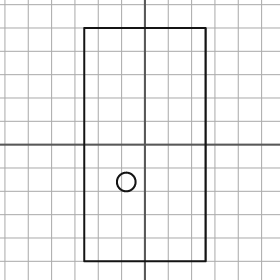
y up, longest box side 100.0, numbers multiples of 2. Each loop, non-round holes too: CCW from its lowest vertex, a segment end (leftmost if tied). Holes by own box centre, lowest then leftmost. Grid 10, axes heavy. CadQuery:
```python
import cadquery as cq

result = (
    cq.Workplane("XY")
    .moveTo(-26.0, -50.0)
    .lineTo(26.0, -50.0)
    .lineTo(26.0, 50.0)
    .lineTo(-26.0, 50.0)
    .close()
    .moveTo(-8.0, -16.0)
    .circle(4.0)
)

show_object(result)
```